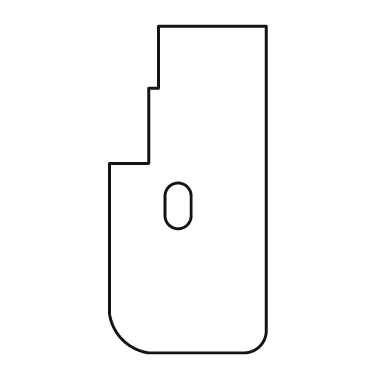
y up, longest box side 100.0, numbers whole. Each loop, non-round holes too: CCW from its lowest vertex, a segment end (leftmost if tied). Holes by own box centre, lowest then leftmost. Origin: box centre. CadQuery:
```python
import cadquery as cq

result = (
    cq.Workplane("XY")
    .moveTo(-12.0, -50.0)
    .lineTo(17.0, -50.0)
    .threePointArc((22.0, -48.0), (24.0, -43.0))
    .lineTo(24.0, 50.0)
    .lineTo(-9.0, 50.0)
    .lineTo(-9.0, 31.0)
    .lineTo(-12.0, 31.0)
    .lineTo(-12.0, 8.0)
    .lineTo(-24.0, 8.0)
    .lineTo(-24.0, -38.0)
    .threePointArc((-20.0, -46.0), (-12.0, -50.0))
    .close()
    .moveTo(-7.0, -8.0)
    .threePointArc((-3.0, -12.0), (1.0, -8.0))
    .lineTo(1.0, -2.0)
    .threePointArc((-3.0, 2.0), (-7.0, -2.0))
    .close()
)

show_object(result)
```